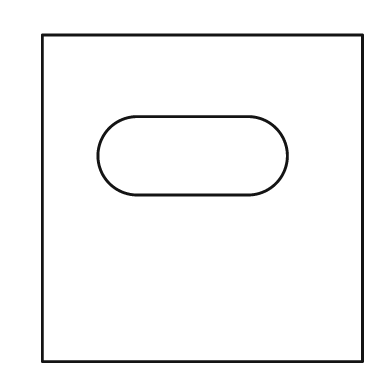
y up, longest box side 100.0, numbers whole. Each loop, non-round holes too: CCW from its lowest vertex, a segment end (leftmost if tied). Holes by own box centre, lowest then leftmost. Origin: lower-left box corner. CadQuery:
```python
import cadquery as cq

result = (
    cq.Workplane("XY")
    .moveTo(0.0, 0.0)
    .lineTo(98.0, 0.0)
    .lineTo(98.0, 100.0)
    .lineTo(0.0, 100.0)
    .close()
    .moveTo(29.0, 51.0)
    .lineTo(63.0, 51.0)
    .threePointArc((75.0, 63.0), (63.0, 75.0))
    .lineTo(29.0, 75.0)
    .threePointArc((17.0, 63.0), (29.0, 51.0))
    .close()
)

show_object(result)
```